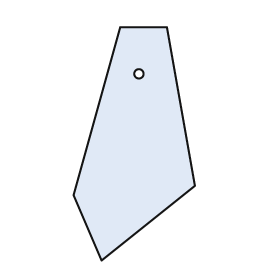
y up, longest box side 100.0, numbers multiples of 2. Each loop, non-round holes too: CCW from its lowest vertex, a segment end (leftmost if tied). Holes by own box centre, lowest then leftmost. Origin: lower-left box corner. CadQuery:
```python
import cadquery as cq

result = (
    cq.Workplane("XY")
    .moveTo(12.0, 0.0)
    .lineTo(52.0, 32.0)
    .lineTo(40.0, 100.0)
    .lineTo(20.0, 100.0)
    .lineTo(0.0, 28.0)
    .close()
    .moveTo(28.0, 80.0)
    .circle(2.0)
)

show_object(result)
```